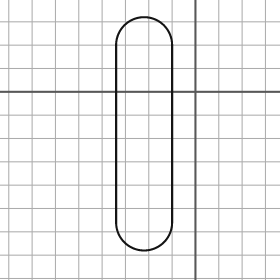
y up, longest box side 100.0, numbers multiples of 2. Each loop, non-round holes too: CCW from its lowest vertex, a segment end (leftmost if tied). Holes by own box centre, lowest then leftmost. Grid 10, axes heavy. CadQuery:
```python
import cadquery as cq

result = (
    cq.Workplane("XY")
    .moveTo(-34.0, -56.0)
    .threePointArc((-22.0, -68.0), (-10.0, -56.0))
    .lineTo(-10.0, 20.0)
    .threePointArc((-22.0, 32.0), (-34.0, 20.0))
    .close()
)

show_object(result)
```